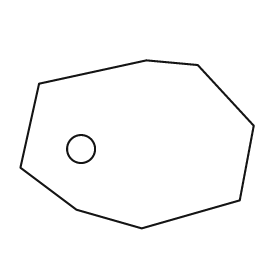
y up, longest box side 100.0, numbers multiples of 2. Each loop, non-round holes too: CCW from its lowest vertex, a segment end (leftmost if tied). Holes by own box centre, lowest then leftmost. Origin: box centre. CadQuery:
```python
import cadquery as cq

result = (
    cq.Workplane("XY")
    .moveTo(2.0, -36.0)
    .lineTo(44.0, -24.0)
    .lineTo(50.0, 8.0)
    .lineTo(26.0, 34.0)
    .lineTo(4.0, 36.0)
    .lineTo(-42.0, 26.0)
    .lineTo(-50.0, -10.0)
    .lineTo(-26.0, -28.0)
    .close()
    .moveTo(-24.0, -2.0)
    .circle(6.0)
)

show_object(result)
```